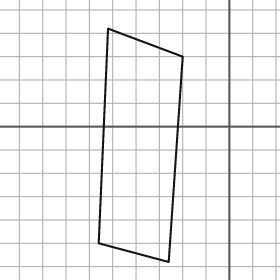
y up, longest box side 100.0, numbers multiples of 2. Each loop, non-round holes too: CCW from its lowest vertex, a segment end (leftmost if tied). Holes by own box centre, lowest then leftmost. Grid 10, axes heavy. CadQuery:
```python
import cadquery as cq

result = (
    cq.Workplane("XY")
    .moveTo(-26.0, -58.0)
    .lineTo(-20.0, 30.0)
    .lineTo(-52.0, 42.0)
    .lineTo(-56.0, -50.0)
    .close()
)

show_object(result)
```